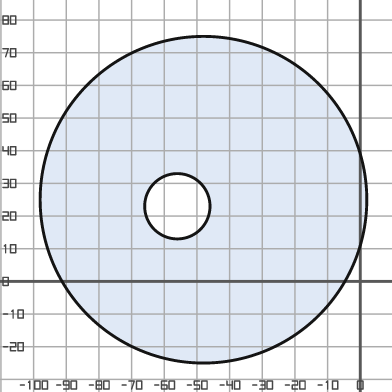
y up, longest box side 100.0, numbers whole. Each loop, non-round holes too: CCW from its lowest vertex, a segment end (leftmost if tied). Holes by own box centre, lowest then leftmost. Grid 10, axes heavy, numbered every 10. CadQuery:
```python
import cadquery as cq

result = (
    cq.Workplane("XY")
    .moveTo(-48.0, 25.0)
    .circle(50.0)
    .moveTo(-56.0, 23.0)
    .circle(10.0)
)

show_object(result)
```